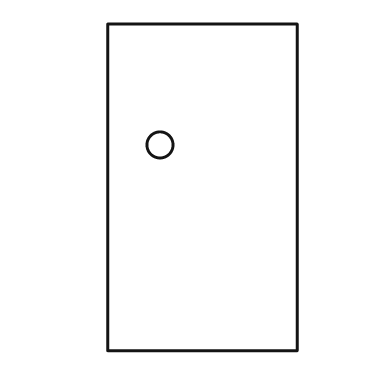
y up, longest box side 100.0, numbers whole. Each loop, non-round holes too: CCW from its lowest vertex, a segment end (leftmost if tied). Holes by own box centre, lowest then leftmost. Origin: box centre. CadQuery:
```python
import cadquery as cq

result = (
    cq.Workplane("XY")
    .moveTo(-29.0, -50.0)
    .lineTo(29.0, -50.0)
    .lineTo(29.0, 50.0)
    .lineTo(-29.0, 50.0)
    .close()
    .moveTo(-13.0, 13.0)
    .circle(4.0)
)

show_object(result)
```